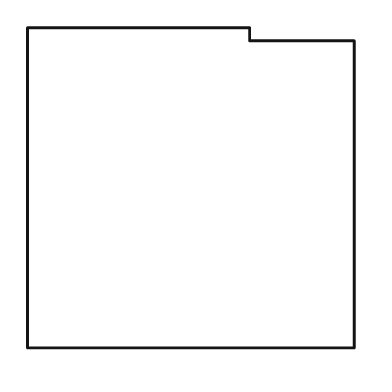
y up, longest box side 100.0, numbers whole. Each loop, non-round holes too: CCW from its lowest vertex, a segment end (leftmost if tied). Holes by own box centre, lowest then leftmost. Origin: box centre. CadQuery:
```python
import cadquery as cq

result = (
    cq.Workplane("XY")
    .moveTo(-50.0, -49.0)
    .lineTo(50.0, -49.0)
    .lineTo(50.0, 45.0)
    .lineTo(18.0, 45.0)
    .lineTo(18.0, 49.0)
    .lineTo(-50.0, 49.0)
    .close()
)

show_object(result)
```